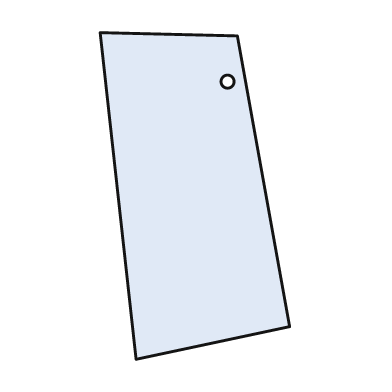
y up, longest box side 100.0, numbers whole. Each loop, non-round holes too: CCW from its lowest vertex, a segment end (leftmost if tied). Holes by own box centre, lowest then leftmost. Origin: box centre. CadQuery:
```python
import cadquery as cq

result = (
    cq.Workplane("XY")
    .moveTo(-18.0, -50.0)
    .lineTo(29.0, -40.0)
    .lineTo(13.0, 49.0)
    .lineTo(-29.0, 50.0)
    .close()
    .moveTo(10.0, 35.0)
    .circle(2.0)
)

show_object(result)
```